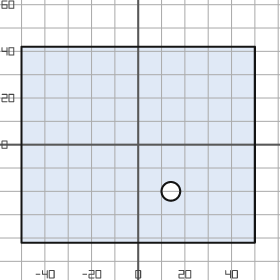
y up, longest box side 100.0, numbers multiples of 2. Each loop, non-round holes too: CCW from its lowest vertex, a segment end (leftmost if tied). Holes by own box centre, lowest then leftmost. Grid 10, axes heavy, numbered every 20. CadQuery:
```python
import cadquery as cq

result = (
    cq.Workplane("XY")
    .moveTo(-50.0, -42.0)
    .lineTo(50.0, -42.0)
    .lineTo(50.0, 42.0)
    .lineTo(-50.0, 42.0)
    .close()
    .moveTo(14.0, -20.0)
    .circle(4.0)
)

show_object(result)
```